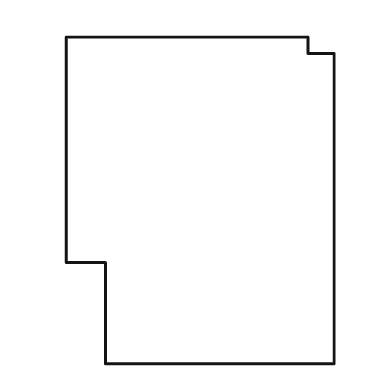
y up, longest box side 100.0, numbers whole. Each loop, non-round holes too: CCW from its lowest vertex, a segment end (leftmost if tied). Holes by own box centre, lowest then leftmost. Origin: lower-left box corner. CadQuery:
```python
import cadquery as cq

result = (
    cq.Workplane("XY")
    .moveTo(12.0, 0.0)
    .lineTo(82.0, 0.0)
    .lineTo(82.0, 95.0)
    .lineTo(74.0, 95.0)
    .lineTo(74.0, 100.0)
    .lineTo(0.0, 100.0)
    .lineTo(0.0, 31.0)
    .lineTo(12.0, 31.0)
    .close()
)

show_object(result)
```